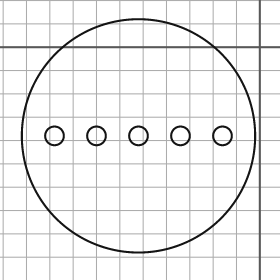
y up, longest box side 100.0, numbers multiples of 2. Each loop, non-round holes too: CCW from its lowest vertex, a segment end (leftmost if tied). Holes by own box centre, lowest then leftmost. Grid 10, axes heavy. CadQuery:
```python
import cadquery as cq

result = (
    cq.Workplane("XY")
    .moveTo(-52.0, -38.0)
    .circle(50.0)
    .moveTo(-88.0, -38.0)
    .circle(4.0)
    .moveTo(-70.0, -38.0)
    .circle(4.0)
    .moveTo(-52.0, -38.0)
    .circle(4.0)
    .moveTo(-34.0, -38.0)
    .circle(4.0)
    .moveTo(-16.0, -38.0)
    .circle(4.0)
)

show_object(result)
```